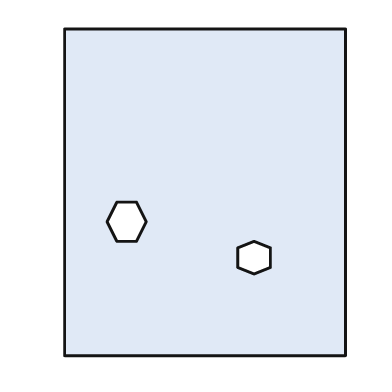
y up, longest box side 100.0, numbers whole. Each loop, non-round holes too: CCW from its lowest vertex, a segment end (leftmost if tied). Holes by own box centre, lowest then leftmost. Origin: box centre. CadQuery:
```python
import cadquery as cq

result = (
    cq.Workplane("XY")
    .moveTo(-43.0, -50.0)
    .lineTo(43.0, -50.0)
    .lineTo(43.0, 50.0)
    .lineTo(-43.0, 50.0)
    .close()
    .moveTo(15.0, -25.0)
    .lineTo(20.0, -23.0)
    .lineTo(20.0, -17.0)
    .lineTo(15.0, -15.0)
    .lineTo(10.0, -17.0)
    .lineTo(10.0, -23.0)
    .close()
    .moveTo(-27.0, -15.0)
    .lineTo(-21.0, -15.0)
    .lineTo(-18.0, -9.0)
    .lineTo(-21.0, -3.0)
    .lineTo(-27.0, -3.0)
    .lineTo(-30.0, -9.0)
    .close()
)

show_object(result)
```